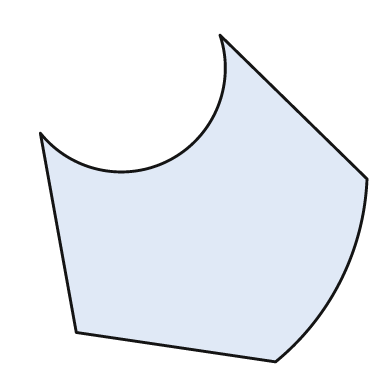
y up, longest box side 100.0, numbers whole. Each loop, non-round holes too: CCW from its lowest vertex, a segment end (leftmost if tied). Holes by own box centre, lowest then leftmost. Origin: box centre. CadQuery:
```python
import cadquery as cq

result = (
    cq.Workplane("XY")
    .moveTo(22.0, -50.0)
    .threePointArc((42.0, -25.0), (50.0, 6.0))
    .lineTo(5.0, 50.0)
    .threePointArc((-10.0, 12.0), (-50.0, 20.0))
    .lineTo(-39.0, -41.0)
    .close()
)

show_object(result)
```